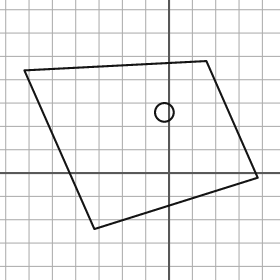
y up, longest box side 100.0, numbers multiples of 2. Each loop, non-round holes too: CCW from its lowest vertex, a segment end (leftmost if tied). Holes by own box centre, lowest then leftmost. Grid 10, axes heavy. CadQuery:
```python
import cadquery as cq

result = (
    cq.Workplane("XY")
    .moveTo(-32.0, -24.0)
    .lineTo(38.0, -2.0)
    .lineTo(16.0, 48.0)
    .lineTo(-62.0, 44.0)
    .close()
    .moveTo(-2.0, 26.0)
    .circle(4.0)
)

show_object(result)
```